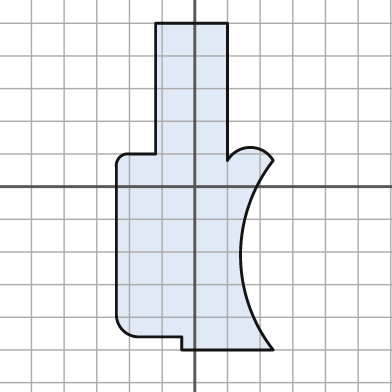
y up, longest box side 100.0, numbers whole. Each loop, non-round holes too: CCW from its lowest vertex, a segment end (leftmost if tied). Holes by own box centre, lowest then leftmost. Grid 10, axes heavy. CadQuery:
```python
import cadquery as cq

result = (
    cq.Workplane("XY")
    .moveTo(-4.0, -50.0)
    .lineTo(24.0, -50.0)
    .threePointArc((14.0, -21.0), (24.0, 8.0))
    .threePointArc((17.0, 12.0), (10.0, 8.0))
    .lineTo(10.0, 50.0)
    .lineTo(-12.0, 50.0)
    .lineTo(-12.0, 10.0)
    .lineTo(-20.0, 10.0)
    .threePointArc((-23.0, 9.0), (-24.0, 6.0))
    .lineTo(-24.0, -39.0)
    .threePointArc((-22.0, -44.0), (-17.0, -46.0))
    .lineTo(-4.0, -46.0)
    .close()
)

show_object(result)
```